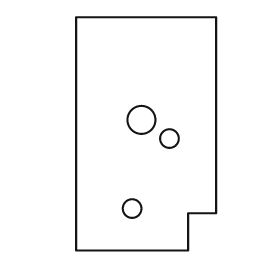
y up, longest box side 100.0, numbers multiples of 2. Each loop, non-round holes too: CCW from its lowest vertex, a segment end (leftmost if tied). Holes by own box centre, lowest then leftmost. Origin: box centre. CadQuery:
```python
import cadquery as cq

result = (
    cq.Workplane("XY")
    .moveTo(-30.0, -50.0)
    .lineTo(18.0, -50.0)
    .lineTo(18.0, -34.0)
    .lineTo(30.0, -34.0)
    .lineTo(30.0, 50.0)
    .lineTo(-30.0, 50.0)
    .close()
    .moveTo(-6.0, -32.0)
    .circle(4.0)
    .moveTo(10.0, -2.0)
    .circle(4.0)
    .moveTo(-2.0, 6.0)
    .circle(6.0)
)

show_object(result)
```